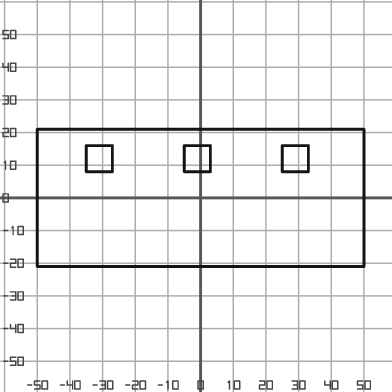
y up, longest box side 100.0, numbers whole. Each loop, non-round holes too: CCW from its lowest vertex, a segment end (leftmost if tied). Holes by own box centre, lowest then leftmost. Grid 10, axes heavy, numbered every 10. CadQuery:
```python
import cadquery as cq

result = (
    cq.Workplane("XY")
    .moveTo(-50.0, -21.0)
    .lineTo(50.0, -21.0)
    .lineTo(50.0, 21.0)
    .lineTo(-50.0, 21.0)
    .close()
    .moveTo(-35.0, 8.0)
    .lineTo(-27.0, 8.0)
    .lineTo(-27.0, 16.0)
    .lineTo(-35.0, 16.0)
    .close()
    .moveTo(-5.0, 8.0)
    .lineTo(3.0, 8.0)
    .lineTo(3.0, 16.0)
    .lineTo(-5.0, 16.0)
    .close()
    .moveTo(25.0, 8.0)
    .lineTo(33.0, 8.0)
    .lineTo(33.0, 16.0)
    .lineTo(25.0, 16.0)
    .close()
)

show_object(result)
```